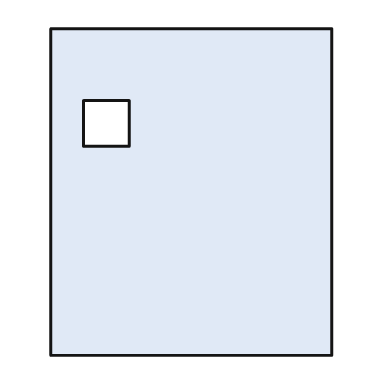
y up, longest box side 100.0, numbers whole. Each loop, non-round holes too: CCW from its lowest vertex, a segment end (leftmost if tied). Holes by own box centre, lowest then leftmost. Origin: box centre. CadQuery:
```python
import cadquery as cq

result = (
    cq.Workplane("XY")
    .moveTo(-43.0, -50.0)
    .lineTo(43.0, -50.0)
    .lineTo(43.0, 50.0)
    .lineTo(-43.0, 50.0)
    .close()
    .moveTo(-33.0, 14.0)
    .lineTo(-19.0, 14.0)
    .lineTo(-19.0, 28.0)
    .lineTo(-33.0, 28.0)
    .close()
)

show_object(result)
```